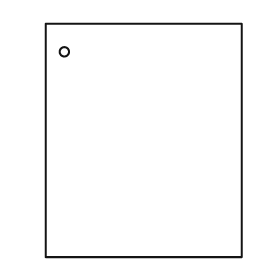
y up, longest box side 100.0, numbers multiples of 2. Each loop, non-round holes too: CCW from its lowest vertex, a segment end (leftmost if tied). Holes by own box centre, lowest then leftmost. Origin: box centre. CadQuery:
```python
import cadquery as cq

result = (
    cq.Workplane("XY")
    .moveTo(-42.0, -50.0)
    .lineTo(42.0, -50.0)
    .lineTo(42.0, 50.0)
    .lineTo(-42.0, 50.0)
    .close()
    .moveTo(-34.0, 38.0)
    .circle(2.0)
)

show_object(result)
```